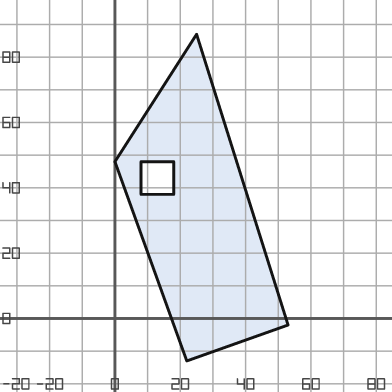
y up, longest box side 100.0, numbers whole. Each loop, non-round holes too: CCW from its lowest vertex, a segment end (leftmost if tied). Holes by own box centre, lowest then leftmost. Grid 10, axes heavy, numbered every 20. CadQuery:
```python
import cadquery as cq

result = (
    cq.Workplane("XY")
    .moveTo(22.0, -13.0)
    .lineTo(53.0, -2.0)
    .lineTo(25.0, 87.0)
    .lineTo(0.0, 48.0)
    .close()
    .moveTo(8.0, 38.0)
    .lineTo(18.0, 38.0)
    .lineTo(18.0, 48.0)
    .lineTo(8.0, 48.0)
    .close()
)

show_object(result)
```